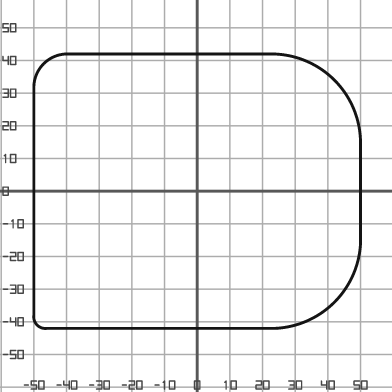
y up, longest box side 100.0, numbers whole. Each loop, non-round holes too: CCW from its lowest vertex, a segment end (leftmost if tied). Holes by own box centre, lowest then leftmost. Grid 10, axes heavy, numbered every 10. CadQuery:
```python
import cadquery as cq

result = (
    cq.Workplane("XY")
    .moveTo(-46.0, -42.0)
    .lineTo(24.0, -42.0)
    .threePointArc((42.0, -34.0), (50.0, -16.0))
    .lineTo(50.0, 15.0)
    .threePointArc((42.0, 34.0), (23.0, 42.0))
    .lineTo(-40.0, 42.0)
    .threePointArc((-47.0, 39.0), (-50.0, 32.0))
    .lineTo(-50.0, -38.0)
    .threePointArc((-49.0, -41.0), (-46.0, -42.0))
    .close()
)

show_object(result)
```